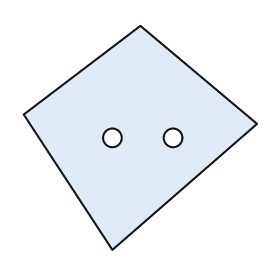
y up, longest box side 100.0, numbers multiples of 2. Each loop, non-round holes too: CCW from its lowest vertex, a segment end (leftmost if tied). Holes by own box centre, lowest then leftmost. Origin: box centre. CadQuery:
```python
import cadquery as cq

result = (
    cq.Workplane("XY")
    .moveTo(-12.0, -48.0)
    .lineTo(50.0, 6.0)
    .lineTo(0.0, 48.0)
    .lineTo(-50.0, 10.0)
    .close()
    .moveTo(-12.0, 0.0)
    .circle(4.0)
    .moveTo(14.0, 0.0)
    .circle(4.0)
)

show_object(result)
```